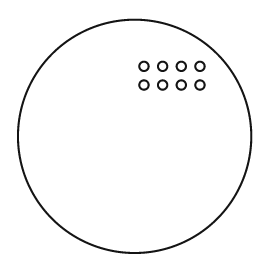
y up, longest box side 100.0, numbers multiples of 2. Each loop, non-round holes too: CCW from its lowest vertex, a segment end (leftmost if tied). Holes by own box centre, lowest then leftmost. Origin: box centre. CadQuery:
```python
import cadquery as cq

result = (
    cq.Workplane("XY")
    .moveTo(0.0, 0.0)
    .circle(50.0)
    .moveTo(4.0, 22.0)
    .circle(2.0)
    .moveTo(12.0, 22.0)
    .circle(2.0)
    .moveTo(20.0, 22.0)
    .circle(2.0)
    .moveTo(28.0, 22.0)
    .circle(2.0)
    .moveTo(4.0, 30.0)
    .circle(2.0)
    .moveTo(12.0, 30.0)
    .circle(2.0)
    .moveTo(20.0, 30.0)
    .circle(2.0)
    .moveTo(28.0, 30.0)
    .circle(2.0)
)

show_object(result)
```